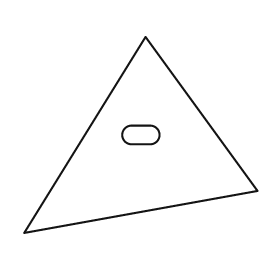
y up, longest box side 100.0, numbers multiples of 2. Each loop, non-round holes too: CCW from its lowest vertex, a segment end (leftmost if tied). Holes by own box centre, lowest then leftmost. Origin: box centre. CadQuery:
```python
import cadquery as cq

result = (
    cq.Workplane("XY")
    .moveTo(-50.0, -42.0)
    .lineTo(50.0, -24.0)
    .lineTo(2.0, 42.0)
    .close()
    .moveTo(-4.0, -4.0)
    .lineTo(4.0, -4.0)
    .threePointArc((8.0, 0.0), (4.0, 4.0))
    .lineTo(-4.0, 4.0)
    .threePointArc((-8.0, 0.0), (-4.0, -4.0))
    .close()
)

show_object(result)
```